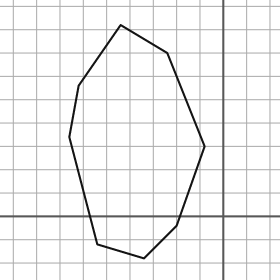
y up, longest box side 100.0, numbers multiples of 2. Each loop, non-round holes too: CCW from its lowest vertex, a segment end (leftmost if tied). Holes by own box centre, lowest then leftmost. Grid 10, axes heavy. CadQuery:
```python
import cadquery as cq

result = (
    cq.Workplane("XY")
    .moveTo(-34.0, -18.0)
    .lineTo(-20.0, -4.0)
    .lineTo(-8.0, 30.0)
    .lineTo(-24.0, 70.0)
    .lineTo(-44.0, 82.0)
    .lineTo(-62.0, 56.0)
    .lineTo(-66.0, 34.0)
    .lineTo(-54.0, -12.0)
    .close()
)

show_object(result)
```